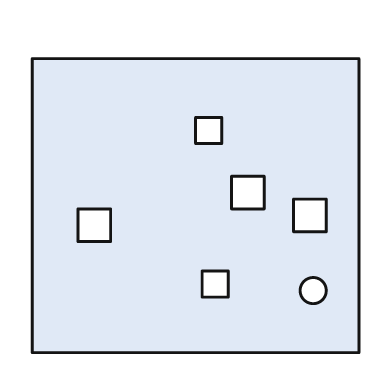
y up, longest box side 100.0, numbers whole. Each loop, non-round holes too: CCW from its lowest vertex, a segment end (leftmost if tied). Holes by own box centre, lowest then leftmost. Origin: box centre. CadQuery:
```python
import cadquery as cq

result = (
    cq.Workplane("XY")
    .moveTo(-50.0, -45.0)
    .lineTo(50.0, -45.0)
    .lineTo(50.0, 45.0)
    .lineTo(-50.0, 45.0)
    .close()
    .moveTo(36.0, -26.0)
    .circle(4.0)
    .moveTo(2.0, -28.0)
    .lineTo(10.0, -28.0)
    .lineTo(10.0, -20.0)
    .lineTo(2.0, -20.0)
    .close()
    .moveTo(-36.0, -11.0)
    .lineTo(-26.0, -11.0)
    .lineTo(-26.0, -1.0)
    .lineTo(-36.0, -1.0)
    .close()
    .moveTo(30.0, -8.0)
    .lineTo(40.0, -8.0)
    .lineTo(40.0, 2.0)
    .lineTo(30.0, 2.0)
    .close()
    .moveTo(11.0, -1.0)
    .lineTo(21.0, -1.0)
    .lineTo(21.0, 9.0)
    .lineTo(11.0, 9.0)
    .close()
    .moveTo(0.0, 19.0)
    .lineTo(8.0, 19.0)
    .lineTo(8.0, 27.0)
    .lineTo(0.0, 27.0)
    .close()
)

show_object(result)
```